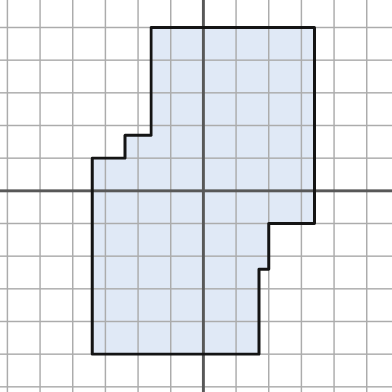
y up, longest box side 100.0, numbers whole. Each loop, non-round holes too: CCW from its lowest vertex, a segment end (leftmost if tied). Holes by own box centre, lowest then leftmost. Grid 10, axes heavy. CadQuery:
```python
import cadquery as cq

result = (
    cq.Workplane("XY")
    .moveTo(-34.0, -50.0)
    .lineTo(17.0, -50.0)
    .lineTo(17.0, -24.0)
    .lineTo(20.0, -24.0)
    .lineTo(20.0, -10.0)
    .lineTo(34.0, -10.0)
    .lineTo(34.0, 50.0)
    .lineTo(-16.0, 50.0)
    .lineTo(-16.0, 17.0)
    .lineTo(-24.0, 17.0)
    .lineTo(-24.0, 10.0)
    .lineTo(-34.0, 10.0)
    .close()
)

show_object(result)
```